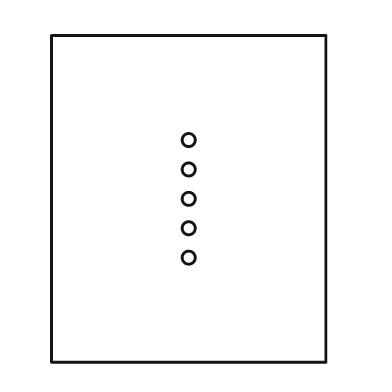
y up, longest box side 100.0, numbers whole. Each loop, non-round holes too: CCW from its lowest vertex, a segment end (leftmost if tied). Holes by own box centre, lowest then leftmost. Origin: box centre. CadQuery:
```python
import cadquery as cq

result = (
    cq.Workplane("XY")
    .moveTo(-42.0, -50.0)
    .lineTo(42.0, -50.0)
    .lineTo(42.0, 50.0)
    .lineTo(-42.0, 50.0)
    .close()
    .moveTo(0.0, -18.0)
    .circle(2.0)
    .moveTo(0.0, -9.0)
    .circle(2.0)
    .moveTo(0.0, 0.0)
    .circle(2.0)
    .moveTo(0.0, 9.0)
    .circle(2.0)
    .moveTo(0.0, 18.0)
    .circle(2.0)
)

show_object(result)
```